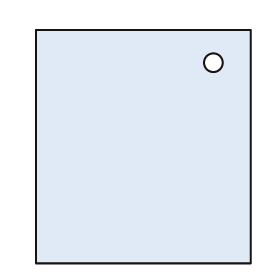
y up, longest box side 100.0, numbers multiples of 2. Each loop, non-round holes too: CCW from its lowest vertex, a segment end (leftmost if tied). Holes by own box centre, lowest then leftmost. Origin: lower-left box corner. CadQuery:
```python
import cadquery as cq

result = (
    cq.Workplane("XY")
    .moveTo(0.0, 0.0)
    .lineTo(92.0, 0.0)
    .lineTo(92.0, 100.0)
    .lineTo(0.0, 100.0)
    .close()
    .moveTo(76.0, 86.0)
    .circle(4.0)
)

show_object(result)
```